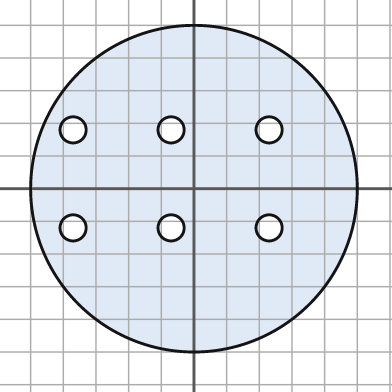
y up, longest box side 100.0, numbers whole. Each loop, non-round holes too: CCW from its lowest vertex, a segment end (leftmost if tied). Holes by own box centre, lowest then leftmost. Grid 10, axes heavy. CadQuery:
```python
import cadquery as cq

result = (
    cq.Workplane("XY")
    .moveTo(0.0, 0.0)
    .circle(50.0)
    .moveTo(-37.0, -12.0)
    .circle(4.0)
    .moveTo(-7.0, -12.0)
    .circle(4.0)
    .moveTo(23.0, -12.0)
    .circle(4.0)
    .moveTo(-37.0, 18.0)
    .circle(4.0)
    .moveTo(-7.0, 18.0)
    .circle(4.0)
    .moveTo(23.0, 18.0)
    .circle(4.0)
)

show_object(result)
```